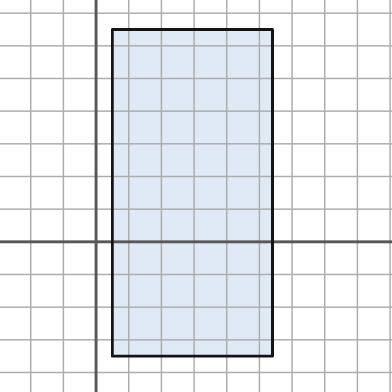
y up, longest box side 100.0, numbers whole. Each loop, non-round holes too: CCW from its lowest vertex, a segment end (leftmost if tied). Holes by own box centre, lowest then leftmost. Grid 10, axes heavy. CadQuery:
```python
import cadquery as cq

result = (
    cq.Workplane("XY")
    .moveTo(5.0, -35.0)
    .lineTo(54.0, -35.0)
    .lineTo(54.0, 65.0)
    .lineTo(5.0, 65.0)
    .close()
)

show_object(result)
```